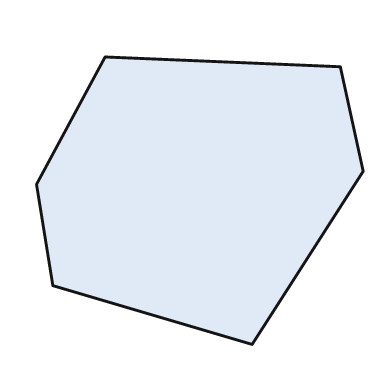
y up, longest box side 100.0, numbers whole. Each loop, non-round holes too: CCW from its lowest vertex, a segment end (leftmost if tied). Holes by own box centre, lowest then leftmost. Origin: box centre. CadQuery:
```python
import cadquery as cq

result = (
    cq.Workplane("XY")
    .moveTo(16.0, -44.0)
    .lineTo(50.0, 9.0)
    .lineTo(43.0, 41.0)
    .lineTo(-29.0, 44.0)
    .lineTo(-50.0, 5.0)
    .lineTo(-45.0, -26.0)
    .close()
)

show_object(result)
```